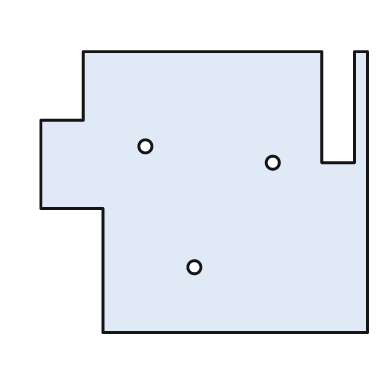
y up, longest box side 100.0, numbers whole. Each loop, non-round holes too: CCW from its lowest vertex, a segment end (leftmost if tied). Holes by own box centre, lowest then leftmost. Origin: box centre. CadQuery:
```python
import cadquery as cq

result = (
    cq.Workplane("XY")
    .moveTo(-31.0, -43.0)
    .lineTo(50.0, -43.0)
    .lineTo(50.0, 43.0)
    .lineTo(46.0, 43.0)
    .lineTo(46.0, 9.0)
    .lineTo(36.0, 9.0)
    .lineTo(36.0, 43.0)
    .lineTo(-37.0, 43.0)
    .lineTo(-37.0, 22.0)
    .lineTo(-50.0, 22.0)
    .lineTo(-50.0, -5.0)
    .lineTo(-31.0, -5.0)
    .close()
    .moveTo(-3.0, -23.0)
    .circle(2.0)
    .moveTo(21.0, 9.0)
    .circle(2.0)
    .moveTo(-18.0, 14.0)
    .circle(2.0)
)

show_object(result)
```